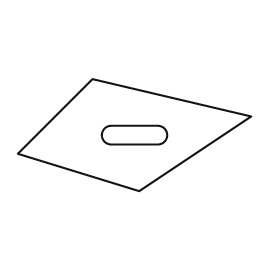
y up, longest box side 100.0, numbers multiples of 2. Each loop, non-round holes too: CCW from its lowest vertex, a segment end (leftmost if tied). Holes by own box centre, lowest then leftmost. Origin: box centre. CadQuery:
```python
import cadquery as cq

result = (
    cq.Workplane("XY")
    .moveTo(2.0, -24.0)
    .lineTo(50.0, 8.0)
    .lineTo(-18.0, 24.0)
    .lineTo(-50.0, -8.0)
    .close()
    .moveTo(-10.0, -4.0)
    .lineTo(10.0, -4.0)
    .threePointArc((14.0, 0.0), (10.0, 4.0))
    .lineTo(-10.0, 4.0)
    .threePointArc((-14.0, 0.0), (-10.0, -4.0))
    .close()
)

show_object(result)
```